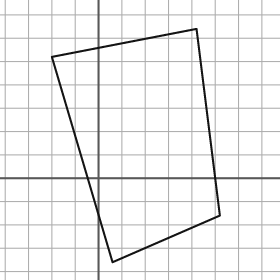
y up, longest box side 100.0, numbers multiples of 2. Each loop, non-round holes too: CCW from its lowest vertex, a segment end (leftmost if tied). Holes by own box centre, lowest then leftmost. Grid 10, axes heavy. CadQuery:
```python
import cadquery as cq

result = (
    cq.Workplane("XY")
    .moveTo(6.0, -36.0)
    .lineTo(52.0, -16.0)
    .lineTo(42.0, 64.0)
    .lineTo(-20.0, 52.0)
    .close()
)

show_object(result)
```